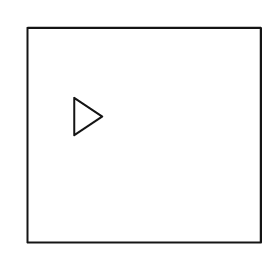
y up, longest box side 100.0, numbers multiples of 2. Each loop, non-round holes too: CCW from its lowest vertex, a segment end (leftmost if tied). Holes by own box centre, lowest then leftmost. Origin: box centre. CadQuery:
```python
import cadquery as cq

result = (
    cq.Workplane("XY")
    .moveTo(-50.0, -46.0)
    .lineTo(50.0, -46.0)
    .lineTo(50.0, 46.0)
    .lineTo(-50.0, 46.0)
    .close()
    .moveTo(-30.0, 0.0)
    .lineTo(-18.0, 8.0)
    .lineTo(-30.0, 16.0)
    .close()
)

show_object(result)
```